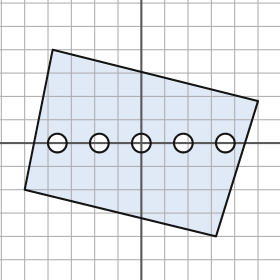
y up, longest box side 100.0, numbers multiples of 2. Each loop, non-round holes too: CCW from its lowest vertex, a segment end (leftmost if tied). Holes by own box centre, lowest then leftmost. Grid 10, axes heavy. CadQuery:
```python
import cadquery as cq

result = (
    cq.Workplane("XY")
    .moveTo(32.0, -40.0)
    .lineTo(50.0, 18.0)
    .lineTo(-38.0, 40.0)
    .lineTo(-50.0, -20.0)
    .close()
    .moveTo(-36.0, 0.0)
    .circle(4.0)
    .moveTo(-18.0, 0.0)
    .circle(4.0)
    .moveTo(0.0, 0.0)
    .circle(4.0)
    .moveTo(18.0, 0.0)
    .circle(4.0)
    .moveTo(36.0, 0.0)
    .circle(4.0)
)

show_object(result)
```